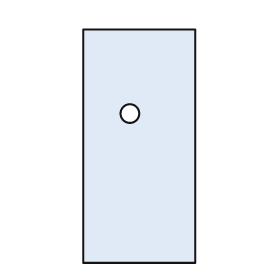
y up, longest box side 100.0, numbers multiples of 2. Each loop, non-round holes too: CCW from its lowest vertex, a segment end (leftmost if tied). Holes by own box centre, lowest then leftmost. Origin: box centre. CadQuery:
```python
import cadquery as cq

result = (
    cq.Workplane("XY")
    .moveTo(-24.0, -50.0)
    .lineTo(24.0, -50.0)
    .lineTo(24.0, 50.0)
    .lineTo(-24.0, 50.0)
    .close()
    .moveTo(-4.0, 14.0)
    .circle(4.0)
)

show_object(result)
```